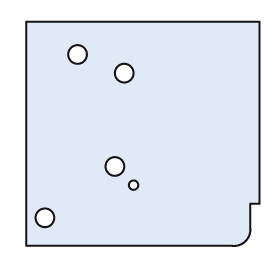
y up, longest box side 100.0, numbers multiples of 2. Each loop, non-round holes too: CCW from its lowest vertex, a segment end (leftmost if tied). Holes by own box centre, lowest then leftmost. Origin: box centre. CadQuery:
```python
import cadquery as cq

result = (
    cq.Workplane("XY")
    .moveTo(-50.0, -48.0)
    .lineTo(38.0, -48.0)
    .threePointArc((44.0, -46.0), (46.0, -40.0))
    .lineTo(46.0, -30.0)
    .lineTo(50.0, -30.0)
    .lineTo(50.0, 48.0)
    .lineTo(-50.0, 48.0)
    .close()
    .moveTo(-42.0, -36.0)
    .circle(4.0)
    .moveTo(-4.0, -22.0)
    .circle(2.0)
    .moveTo(-12.0, -14.0)
    .circle(4.0)
    .moveTo(-8.0, 26.0)
    .circle(4.0)
    .moveTo(-28.0, 34.0)
    .circle(4.0)
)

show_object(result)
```